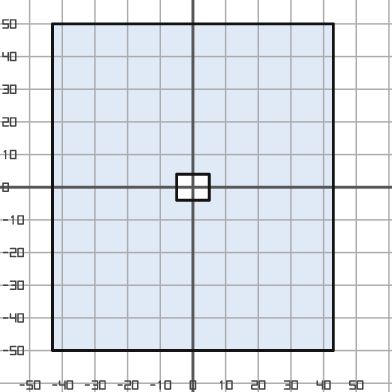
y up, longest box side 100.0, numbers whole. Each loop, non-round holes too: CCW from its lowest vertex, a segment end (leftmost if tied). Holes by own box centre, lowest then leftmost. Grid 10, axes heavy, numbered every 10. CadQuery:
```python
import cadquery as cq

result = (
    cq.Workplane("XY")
    .moveTo(-43.0, -50.0)
    .lineTo(43.0, -50.0)
    .lineTo(43.0, 50.0)
    .lineTo(-43.0, 50.0)
    .close()
    .moveTo(-5.0, -4.0)
    .lineTo(5.0, -4.0)
    .lineTo(5.0, 4.0)
    .lineTo(-5.0, 4.0)
    .close()
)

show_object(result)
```